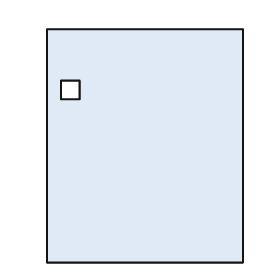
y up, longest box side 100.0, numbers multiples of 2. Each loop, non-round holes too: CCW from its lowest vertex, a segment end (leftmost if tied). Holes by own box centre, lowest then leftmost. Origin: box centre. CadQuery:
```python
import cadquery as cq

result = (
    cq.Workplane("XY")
    .moveTo(-42.0, -50.0)
    .lineTo(42.0, -50.0)
    .lineTo(42.0, 50.0)
    .lineTo(-42.0, 50.0)
    .close()
    .moveTo(-36.0, 20.0)
    .lineTo(-28.0, 20.0)
    .lineTo(-28.0, 28.0)
    .lineTo(-36.0, 28.0)
    .close()
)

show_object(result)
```